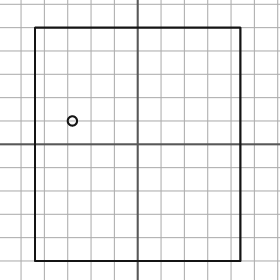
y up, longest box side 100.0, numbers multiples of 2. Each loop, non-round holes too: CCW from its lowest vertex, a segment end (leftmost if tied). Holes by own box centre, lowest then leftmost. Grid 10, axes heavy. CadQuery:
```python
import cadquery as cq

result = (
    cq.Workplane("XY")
    .moveTo(-44.0, -50.0)
    .lineTo(44.0, -50.0)
    .lineTo(44.0, 50.0)
    .lineTo(-44.0, 50.0)
    .close()
    .moveTo(-28.0, 10.0)
    .circle(2.0)
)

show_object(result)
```